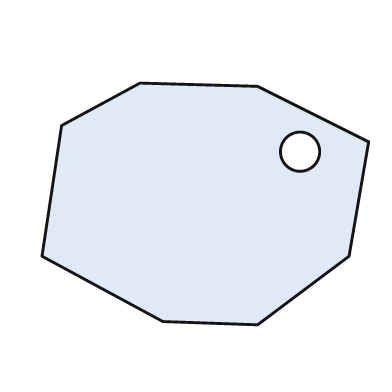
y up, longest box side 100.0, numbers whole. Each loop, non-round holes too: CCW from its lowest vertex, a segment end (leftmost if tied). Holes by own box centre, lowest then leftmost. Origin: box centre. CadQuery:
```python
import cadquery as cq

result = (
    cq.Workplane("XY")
    .moveTo(16.0, -37.0)
    .lineTo(44.0, -16.0)
    .lineTo(50.0, 19.0)
    .lineTo(16.0, 36.0)
    .lineTo(-20.0, 37.0)
    .lineTo(-44.0, 24.0)
    .lineTo(-50.0, -16.0)
    .lineTo(-13.0, -36.0)
    .close()
    .moveTo(29.0, 16.0)
    .circle(6.0)
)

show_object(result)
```